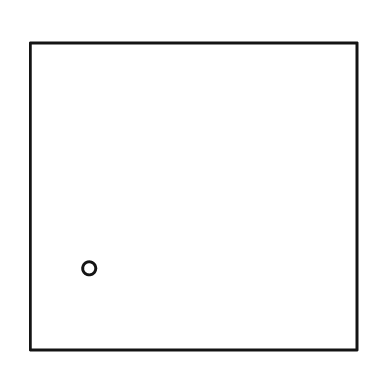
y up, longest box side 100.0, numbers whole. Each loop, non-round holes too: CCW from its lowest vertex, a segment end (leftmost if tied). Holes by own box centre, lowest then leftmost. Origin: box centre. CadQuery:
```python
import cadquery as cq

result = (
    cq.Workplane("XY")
    .moveTo(-50.0, -47.0)
    .lineTo(50.0, -47.0)
    .lineTo(50.0, 47.0)
    .lineTo(-50.0, 47.0)
    .close()
    .moveTo(-32.0, -22.0)
    .circle(2.0)
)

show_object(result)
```